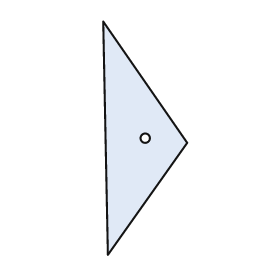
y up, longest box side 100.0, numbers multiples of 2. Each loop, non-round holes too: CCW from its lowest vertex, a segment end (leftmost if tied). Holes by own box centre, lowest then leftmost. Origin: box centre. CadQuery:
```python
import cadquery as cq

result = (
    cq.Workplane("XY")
    .moveTo(-16.0, -50.0)
    .lineTo(18.0, -2.0)
    .lineTo(-18.0, 50.0)
    .close()
    .moveTo(0.0, 0.0)
    .circle(2.0)
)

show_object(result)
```